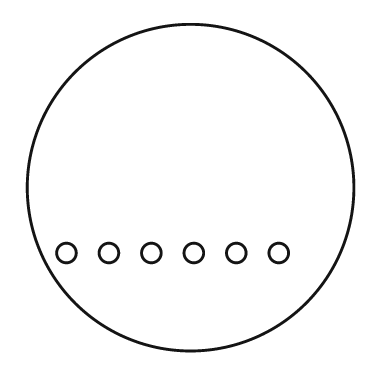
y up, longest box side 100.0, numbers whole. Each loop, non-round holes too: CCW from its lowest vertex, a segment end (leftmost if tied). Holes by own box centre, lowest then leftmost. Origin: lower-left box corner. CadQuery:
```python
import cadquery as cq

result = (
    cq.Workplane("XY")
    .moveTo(50.0, 50.0)
    .circle(50.0)
    .moveTo(12.0, 30.0)
    .circle(3.0)
    .moveTo(25.0, 30.0)
    .circle(3.0)
    .moveTo(38.0, 30.0)
    .circle(3.0)
    .moveTo(51.0, 30.0)
    .circle(3.0)
    .moveTo(64.0, 30.0)
    .circle(3.0)
    .moveTo(77.0, 30.0)
    .circle(3.0)
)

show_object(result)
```